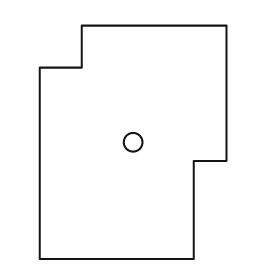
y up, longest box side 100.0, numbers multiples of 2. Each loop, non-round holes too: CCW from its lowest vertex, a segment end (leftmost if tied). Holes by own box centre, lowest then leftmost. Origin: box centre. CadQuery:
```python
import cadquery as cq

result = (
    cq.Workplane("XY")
    .moveTo(-40.0, -50.0)
    .lineTo(26.0, -50.0)
    .lineTo(26.0, -8.0)
    .lineTo(40.0, -8.0)
    .lineTo(40.0, 50.0)
    .lineTo(-22.0, 50.0)
    .lineTo(-22.0, 32.0)
    .lineTo(-40.0, 32.0)
    .close()
    .moveTo(0.0, 0.0)
    .circle(4.0)
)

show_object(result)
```